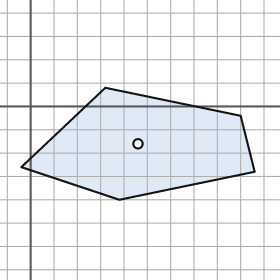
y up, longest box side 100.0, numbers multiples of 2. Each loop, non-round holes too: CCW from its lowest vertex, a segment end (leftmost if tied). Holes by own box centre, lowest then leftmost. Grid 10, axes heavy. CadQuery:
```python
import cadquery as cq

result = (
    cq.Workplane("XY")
    .moveTo(38.0, -40.0)
    .lineTo(96.0, -28.0)
    .lineTo(90.0, -4.0)
    .lineTo(32.0, 8.0)
    .lineTo(-4.0, -26.0)
    .close()
    .moveTo(46.0, -16.0)
    .circle(2.0)
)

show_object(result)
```